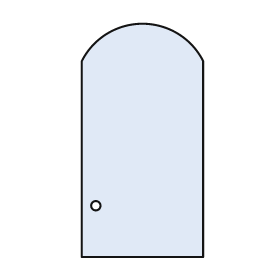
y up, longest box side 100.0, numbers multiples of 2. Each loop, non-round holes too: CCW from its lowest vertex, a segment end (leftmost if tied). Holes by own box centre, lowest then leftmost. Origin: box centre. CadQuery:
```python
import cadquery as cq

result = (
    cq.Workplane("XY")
    .moveTo(-26.0, -50.0)
    .lineTo(26.0, -50.0)
    .lineTo(26.0, 34.0)
    .threePointArc((0.0, 50.0), (-26.0, 34.0))
    .close()
    .moveTo(-20.0, -28.0)
    .circle(2.0)
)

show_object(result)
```